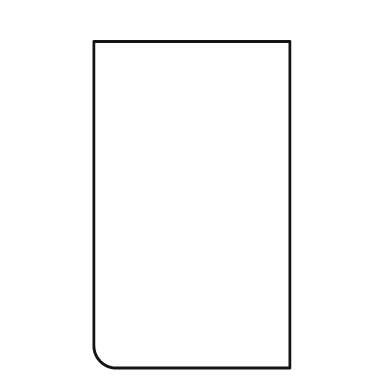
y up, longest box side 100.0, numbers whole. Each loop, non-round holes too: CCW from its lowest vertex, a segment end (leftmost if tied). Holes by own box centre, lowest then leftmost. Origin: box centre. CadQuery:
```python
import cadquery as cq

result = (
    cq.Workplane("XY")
    .moveTo(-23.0, -50.0)
    .lineTo(30.0, -50.0)
    .lineTo(30.0, 50.0)
    .lineTo(-30.0, 50.0)
    .lineTo(-30.0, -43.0)
    .threePointArc((-28.0, -48.0), (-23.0, -50.0))
    .close()
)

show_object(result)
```